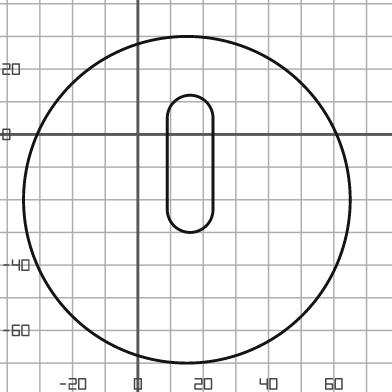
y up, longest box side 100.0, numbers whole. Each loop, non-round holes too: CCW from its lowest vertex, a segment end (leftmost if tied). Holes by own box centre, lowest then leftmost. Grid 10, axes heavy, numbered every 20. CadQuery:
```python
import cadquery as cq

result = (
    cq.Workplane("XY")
    .moveTo(15.0, -20.0)
    .circle(50.0)
    .moveTo(9.0, -23.0)
    .threePointArc((16.0, -30.0), (23.0, -23.0))
    .lineTo(23.0, 5.0)
    .threePointArc((16.0, 12.0), (9.0, 5.0))
    .close()
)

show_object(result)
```